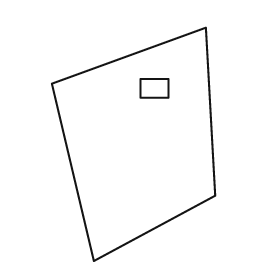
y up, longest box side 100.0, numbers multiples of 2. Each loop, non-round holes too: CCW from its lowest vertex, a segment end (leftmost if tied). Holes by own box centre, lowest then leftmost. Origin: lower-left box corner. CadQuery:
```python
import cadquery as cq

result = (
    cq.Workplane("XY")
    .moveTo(18.0, 0.0)
    .lineTo(70.0, 28.0)
    .lineTo(66.0, 100.0)
    .lineTo(0.0, 76.0)
    .close()
    .moveTo(38.0, 70.0)
    .lineTo(50.0, 70.0)
    .lineTo(50.0, 78.0)
    .lineTo(38.0, 78.0)
    .close()
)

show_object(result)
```